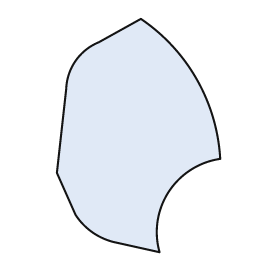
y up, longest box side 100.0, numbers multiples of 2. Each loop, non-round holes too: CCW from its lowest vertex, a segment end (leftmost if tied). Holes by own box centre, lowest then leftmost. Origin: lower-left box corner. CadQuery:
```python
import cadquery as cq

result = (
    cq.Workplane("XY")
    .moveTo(44.0, 0.0)
    .threePointArc((48.0, 26.0), (70.0, 40.0))
    .threePointArc((60.0, 74.0), (36.0, 100.0))
    .lineTo(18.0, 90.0)
    .threePointArc((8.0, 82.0), (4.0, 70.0))
    .lineTo(0.0, 34.0)
    .lineTo(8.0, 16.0)
    .threePointArc((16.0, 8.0), (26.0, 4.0))
    .close()
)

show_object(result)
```